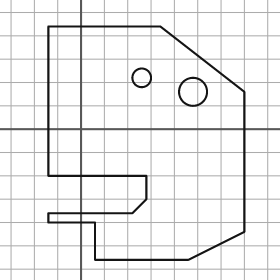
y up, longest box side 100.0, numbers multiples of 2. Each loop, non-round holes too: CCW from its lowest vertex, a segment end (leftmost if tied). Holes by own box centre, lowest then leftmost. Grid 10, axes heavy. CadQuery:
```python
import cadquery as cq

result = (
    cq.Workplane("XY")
    .moveTo(6.0, -56.0)
    .lineTo(46.0, -56.0)
    .lineTo(70.0, -44.0)
    .lineTo(70.0, 16.0)
    .lineTo(34.0, 44.0)
    .lineTo(-14.0, 44.0)
    .lineTo(-14.0, -20.0)
    .lineTo(28.0, -20.0)
    .lineTo(28.0, -30.0)
    .lineTo(22.0, -36.0)
    .lineTo(-14.0, -36.0)
    .lineTo(-14.0, -40.0)
    .lineTo(6.0, -40.0)
    .close()
    .moveTo(48.0, 16.0)
    .circle(6.0)
    .moveTo(26.0, 22.0)
    .circle(4.0)
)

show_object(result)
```